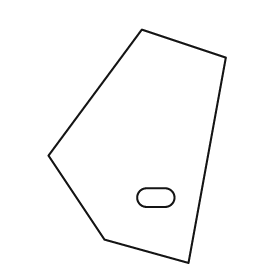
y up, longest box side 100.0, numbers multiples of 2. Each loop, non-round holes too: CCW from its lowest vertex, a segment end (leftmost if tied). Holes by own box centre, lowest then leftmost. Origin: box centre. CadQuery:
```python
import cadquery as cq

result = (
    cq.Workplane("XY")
    .moveTo(22.0, -50.0)
    .lineTo(38.0, 38.0)
    .lineTo(2.0, 50.0)
    .lineTo(-38.0, -4.0)
    .lineTo(-14.0, -40.0)
    .close()
    .moveTo(4.0, -26.0)
    .lineTo(12.0, -26.0)
    .threePointArc((16.0, -22.0), (12.0, -18.0))
    .lineTo(4.0, -18.0)
    .threePointArc((0.0, -22.0), (4.0, -26.0))
    .close()
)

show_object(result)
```